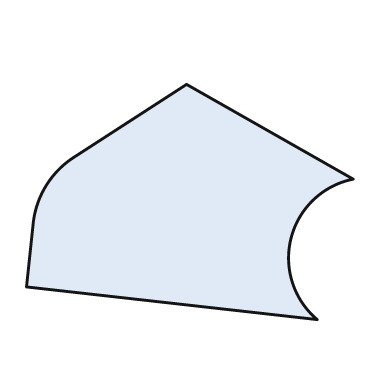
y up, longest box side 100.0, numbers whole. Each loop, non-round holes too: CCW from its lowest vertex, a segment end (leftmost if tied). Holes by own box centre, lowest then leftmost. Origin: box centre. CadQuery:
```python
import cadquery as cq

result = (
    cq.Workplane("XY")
    .moveTo(39.0, -36.0)
    .threePointArc((31.0, -11.0), (50.0, 7.0))
    .lineTo(-1.0, 36.0)
    .lineTo(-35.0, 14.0)
    .threePointArc((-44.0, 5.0), (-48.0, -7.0))
    .lineTo(-50.0, -26.0)
    .close()
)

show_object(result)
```